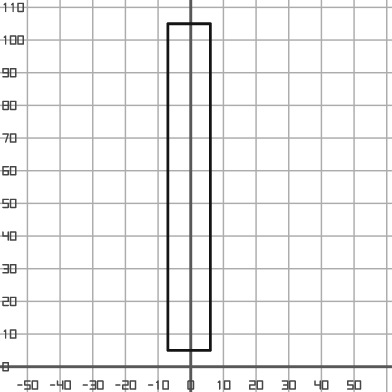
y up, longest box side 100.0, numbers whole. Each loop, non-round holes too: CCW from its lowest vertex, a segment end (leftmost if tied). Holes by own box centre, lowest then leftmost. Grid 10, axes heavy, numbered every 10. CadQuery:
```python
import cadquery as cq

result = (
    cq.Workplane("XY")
    .moveTo(-7.0, 5.0)
    .lineTo(6.0, 5.0)
    .lineTo(6.0, 105.0)
    .lineTo(-7.0, 105.0)
    .close()
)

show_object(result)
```